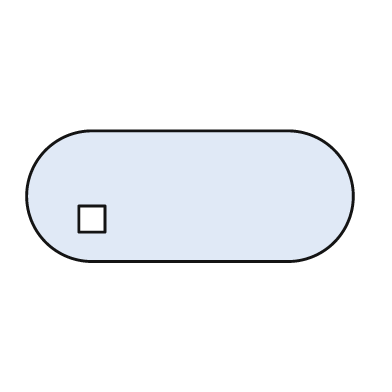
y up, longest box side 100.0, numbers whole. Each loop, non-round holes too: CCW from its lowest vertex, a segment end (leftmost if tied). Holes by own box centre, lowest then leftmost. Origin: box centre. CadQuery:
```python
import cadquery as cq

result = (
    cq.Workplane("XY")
    .moveTo(-30.0, -20.0)
    .lineTo(30.0, -20.0)
    .threePointArc((50.0, 0.0), (30.0, 20.0))
    .lineTo(-30.0, 20.0)
    .threePointArc((-50.0, 0.0), (-30.0, -20.0))
    .close()
    .moveTo(-34.0, -11.0)
    .lineTo(-26.0, -11.0)
    .lineTo(-26.0, -3.0)
    .lineTo(-34.0, -3.0)
    .close()
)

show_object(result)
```